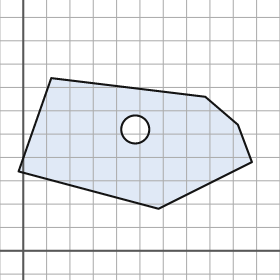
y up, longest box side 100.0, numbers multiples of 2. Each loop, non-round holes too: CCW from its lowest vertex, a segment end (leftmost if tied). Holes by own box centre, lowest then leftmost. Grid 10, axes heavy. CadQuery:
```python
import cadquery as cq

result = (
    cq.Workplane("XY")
    .moveTo(58.0, 18.0)
    .lineTo(98.0, 38.0)
    .lineTo(92.0, 54.0)
    .lineTo(78.0, 66.0)
    .lineTo(12.0, 74.0)
    .lineTo(-2.0, 34.0)
    .close()
    .moveTo(48.0, 52.0)
    .circle(6.0)
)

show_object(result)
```